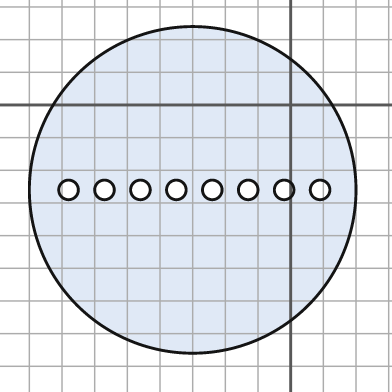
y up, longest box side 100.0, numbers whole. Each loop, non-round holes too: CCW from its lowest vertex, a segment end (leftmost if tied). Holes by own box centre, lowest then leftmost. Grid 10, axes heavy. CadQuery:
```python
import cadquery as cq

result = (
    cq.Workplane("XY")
    .moveTo(-30.0, -26.0)
    .circle(50.0)
    .moveTo(-68.0, -26.0)
    .circle(3.0)
    .moveTo(-57.0, -26.0)
    .circle(3.0)
    .moveTo(-46.0, -26.0)
    .circle(3.0)
    .moveTo(-35.0, -26.0)
    .circle(3.0)
    .moveTo(-24.0, -26.0)
    .circle(3.0)
    .moveTo(-13.0, -26.0)
    .circle(3.0)
    .moveTo(-2.0, -26.0)
    .circle(3.0)
    .moveTo(9.0, -26.0)
    .circle(3.0)
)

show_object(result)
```